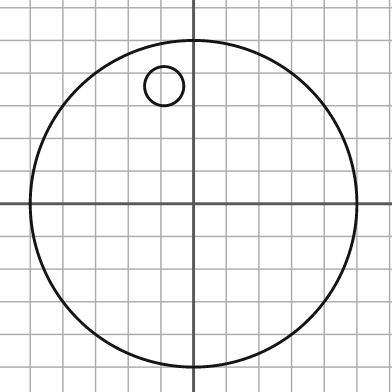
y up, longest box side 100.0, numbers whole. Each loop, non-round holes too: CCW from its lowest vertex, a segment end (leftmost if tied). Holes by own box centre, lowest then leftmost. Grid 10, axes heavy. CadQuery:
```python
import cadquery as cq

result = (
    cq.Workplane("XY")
    .moveTo(0.0, 0.0)
    .circle(50.0)
    .moveTo(-9.0, 36.0)
    .circle(6.0)
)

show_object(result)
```